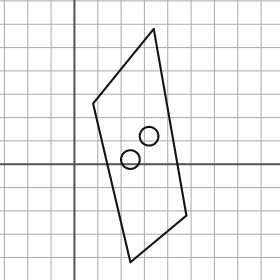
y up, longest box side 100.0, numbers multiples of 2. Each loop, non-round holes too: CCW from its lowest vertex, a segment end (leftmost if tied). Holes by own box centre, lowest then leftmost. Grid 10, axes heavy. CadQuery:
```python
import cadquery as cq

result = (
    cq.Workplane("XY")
    .moveTo(24.0, -42.0)
    .lineTo(48.0, -22.0)
    .lineTo(34.0, 58.0)
    .lineTo(8.0, 26.0)
    .close()
    .moveTo(24.0, 2.0)
    .circle(4.0)
    .moveTo(32.0, 12.0)
    .circle(4.0)
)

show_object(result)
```